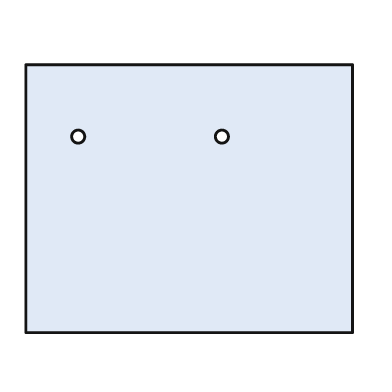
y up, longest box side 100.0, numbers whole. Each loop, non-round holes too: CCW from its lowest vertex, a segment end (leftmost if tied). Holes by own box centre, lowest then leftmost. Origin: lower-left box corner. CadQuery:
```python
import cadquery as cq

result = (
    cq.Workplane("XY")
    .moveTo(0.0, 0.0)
    .lineTo(100.0, 0.0)
    .lineTo(100.0, 82.0)
    .lineTo(0.0, 82.0)
    .close()
    .moveTo(16.0, 60.0)
    .circle(2.0)
    .moveTo(60.0, 60.0)
    .circle(2.0)
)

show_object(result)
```